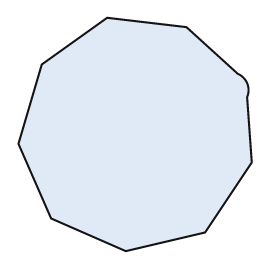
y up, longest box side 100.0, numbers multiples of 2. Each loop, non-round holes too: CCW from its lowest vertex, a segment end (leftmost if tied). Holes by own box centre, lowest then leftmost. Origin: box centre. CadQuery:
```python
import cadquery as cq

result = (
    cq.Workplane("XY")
    .moveTo(-4.0, -50.0)
    .lineTo(30.0, -42.0)
    .lineTo(50.0, -12.0)
    .lineTo(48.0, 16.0)
    .threePointArc((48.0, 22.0), (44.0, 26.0))
    .lineTo(22.0, 46.0)
    .lineTo(-12.0, 50.0)
    .lineTo(-40.0, 30.0)
    .lineTo(-50.0, -4.0)
    .lineTo(-36.0, -36.0)
    .close()
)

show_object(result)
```